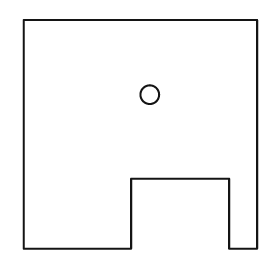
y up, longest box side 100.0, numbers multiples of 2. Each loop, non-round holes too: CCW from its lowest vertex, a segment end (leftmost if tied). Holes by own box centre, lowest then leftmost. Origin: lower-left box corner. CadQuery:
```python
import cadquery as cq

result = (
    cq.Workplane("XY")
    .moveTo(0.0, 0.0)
    .lineTo(46.0, 0.0)
    .lineTo(46.0, 30.0)
    .lineTo(88.0, 30.0)
    .lineTo(88.0, 0.0)
    .lineTo(100.0, 0.0)
    .lineTo(100.0, 98.0)
    .lineTo(0.0, 98.0)
    .close()
    .moveTo(54.0, 66.0)
    .circle(4.0)
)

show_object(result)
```